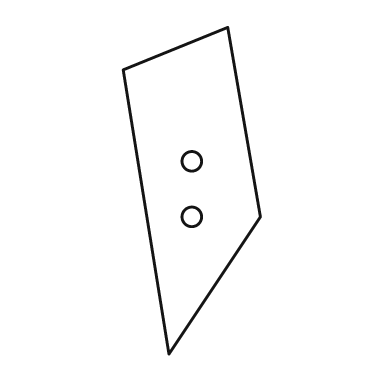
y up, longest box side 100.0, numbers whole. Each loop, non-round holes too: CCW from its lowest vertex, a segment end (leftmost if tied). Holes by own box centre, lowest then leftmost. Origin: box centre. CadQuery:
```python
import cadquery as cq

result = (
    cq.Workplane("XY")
    .moveTo(-7.0, -50.0)
    .lineTo(21.0, -8.0)
    .lineTo(11.0, 50.0)
    .lineTo(-21.0, 37.0)
    .close()
    .moveTo(0.0, -8.0)
    .circle(3.0)
    .moveTo(0.0, 9.0)
    .circle(3.0)
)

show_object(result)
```